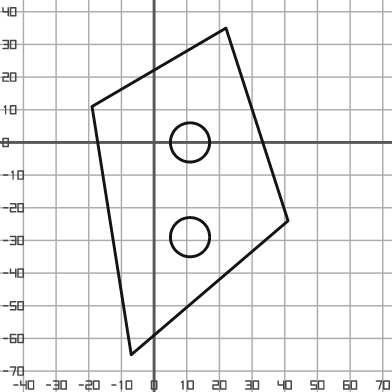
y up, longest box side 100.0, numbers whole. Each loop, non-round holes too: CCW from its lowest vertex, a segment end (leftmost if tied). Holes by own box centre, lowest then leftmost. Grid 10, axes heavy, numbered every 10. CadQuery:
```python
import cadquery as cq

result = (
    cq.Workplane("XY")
    .moveTo(-7.0, -65.0)
    .lineTo(41.0, -24.0)
    .lineTo(22.0, 35.0)
    .lineTo(-19.0, 11.0)
    .close()
    .moveTo(11.0, -29.0)
    .circle(6.0)
    .moveTo(11.0, 0.0)
    .circle(6.0)
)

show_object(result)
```